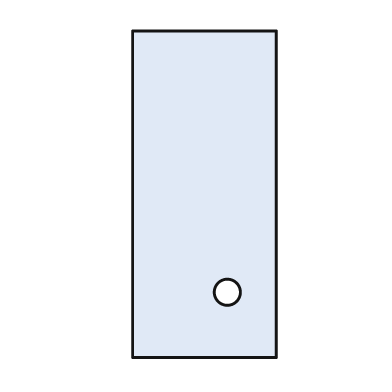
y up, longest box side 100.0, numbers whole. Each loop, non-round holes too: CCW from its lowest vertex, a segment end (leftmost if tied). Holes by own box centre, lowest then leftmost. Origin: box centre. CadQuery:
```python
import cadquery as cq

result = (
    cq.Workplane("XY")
    .moveTo(-22.0, -50.0)
    .lineTo(22.0, -50.0)
    .lineTo(22.0, 50.0)
    .lineTo(-22.0, 50.0)
    .close()
    .moveTo(7.0, -30.0)
    .circle(4.0)
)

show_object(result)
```